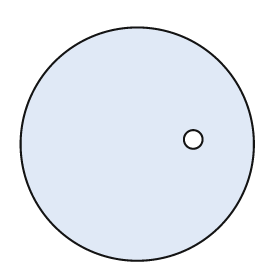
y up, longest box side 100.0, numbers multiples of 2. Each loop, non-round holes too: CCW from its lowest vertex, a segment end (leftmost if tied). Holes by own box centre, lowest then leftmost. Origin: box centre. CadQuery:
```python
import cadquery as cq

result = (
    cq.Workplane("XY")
    .moveTo(0.0, 0.0)
    .circle(50.0)
    .moveTo(24.0, 2.0)
    .circle(4.0)
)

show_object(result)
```